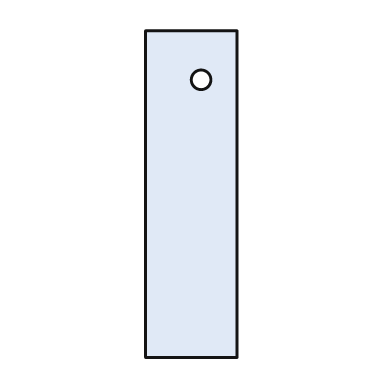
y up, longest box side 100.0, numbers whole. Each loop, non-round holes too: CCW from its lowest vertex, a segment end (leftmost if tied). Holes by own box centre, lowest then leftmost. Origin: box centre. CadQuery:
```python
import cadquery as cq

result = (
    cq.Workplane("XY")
    .moveTo(-14.0, -50.0)
    .lineTo(14.0, -50.0)
    .lineTo(14.0, 50.0)
    .lineTo(-14.0, 50.0)
    .close()
    .moveTo(3.0, 35.0)
    .circle(3.0)
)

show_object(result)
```